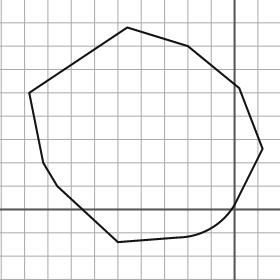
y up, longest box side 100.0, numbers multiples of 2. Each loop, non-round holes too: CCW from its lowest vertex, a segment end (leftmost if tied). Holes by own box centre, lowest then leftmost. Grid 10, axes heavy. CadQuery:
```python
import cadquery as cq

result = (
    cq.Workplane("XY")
    .moveTo(-50.0, -14.0)
    .lineTo(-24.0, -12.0)
    .threePointArc((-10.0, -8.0), (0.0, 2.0))
    .lineTo(12.0, 26.0)
    .lineTo(2.0, 52.0)
    .lineTo(-20.0, 70.0)
    .lineTo(-46.0, 78.0)
    .lineTo(-88.0, 50.0)
    .lineTo(-82.0, 20.0)
    .lineTo(-76.0, 10.0)
    .close()
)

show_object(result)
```